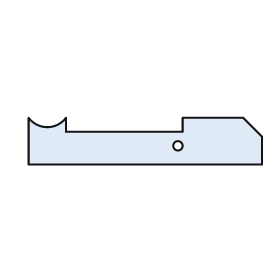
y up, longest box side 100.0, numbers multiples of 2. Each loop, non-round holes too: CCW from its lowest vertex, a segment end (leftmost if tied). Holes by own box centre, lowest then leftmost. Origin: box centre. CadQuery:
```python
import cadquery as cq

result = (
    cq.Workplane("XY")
    .moveTo(-50.0, -10.0)
    .lineTo(50.0, -10.0)
    .lineTo(50.0, 2.0)
    .lineTo(42.0, 10.0)
    .lineTo(16.0, 10.0)
    .lineTo(16.0, 4.0)
    .lineTo(-34.0, 4.0)
    .lineTo(-34.0, 10.0)
    .threePointArc((-42.0, 6.0), (-50.0, 10.0))
    .close()
    .moveTo(14.0, -2.0)
    .circle(2.0)
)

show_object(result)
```